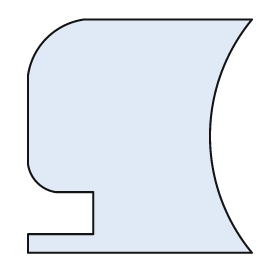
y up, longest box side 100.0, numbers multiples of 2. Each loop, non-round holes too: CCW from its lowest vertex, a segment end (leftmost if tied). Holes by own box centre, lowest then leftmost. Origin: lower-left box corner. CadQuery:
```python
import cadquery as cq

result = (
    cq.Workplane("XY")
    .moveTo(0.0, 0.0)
    .lineTo(96.0, 0.0)
    .threePointArc((78.0, 50.0), (96.0, 100.0))
    .lineTo(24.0, 100.0)
    .threePointArc((8.0, 92.0), (0.0, 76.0))
    .lineTo(0.0, 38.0)
    .threePointArc((4.0, 30.0), (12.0, 26.0))
    .lineTo(28.0, 26.0)
    .lineTo(28.0, 8.0)
    .lineTo(0.0, 8.0)
    .close()
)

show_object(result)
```